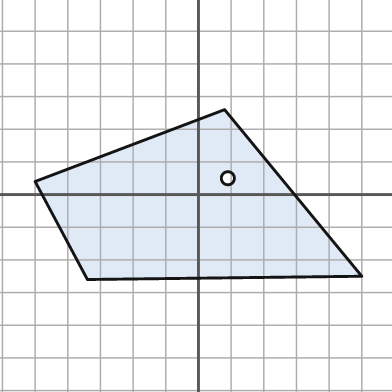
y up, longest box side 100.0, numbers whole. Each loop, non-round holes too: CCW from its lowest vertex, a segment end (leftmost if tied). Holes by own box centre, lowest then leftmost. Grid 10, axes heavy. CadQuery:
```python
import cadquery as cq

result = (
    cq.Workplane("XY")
    .moveTo(-34.0, -26.0)
    .lineTo(50.0, -25.0)
    .lineTo(8.0, 26.0)
    .lineTo(-50.0, 4.0)
    .close()
    .moveTo(9.0, 5.0)
    .circle(2.0)
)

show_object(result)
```